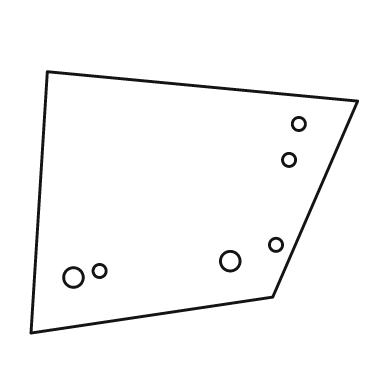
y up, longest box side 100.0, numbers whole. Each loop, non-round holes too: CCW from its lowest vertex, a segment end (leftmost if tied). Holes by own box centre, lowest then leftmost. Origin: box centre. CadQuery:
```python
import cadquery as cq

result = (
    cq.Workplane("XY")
    .moveTo(-50.0, -40.0)
    .lineTo(24.0, -29.0)
    .lineTo(50.0, 31.0)
    .lineTo(-45.0, 40.0)
    .close()
    .moveTo(-37.0, -23.0)
    .circle(3.0)
    .moveTo(-29.0, -21.0)
    .circle(2.0)
    .moveTo(11.0, -18.0)
    .circle(3.0)
    .moveTo(25.0, -13.0)
    .circle(2.0)
    .moveTo(29.0, 13.0)
    .circle(2.0)
    .moveTo(32.0, 24.0)
    .circle(2.0)
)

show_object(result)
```